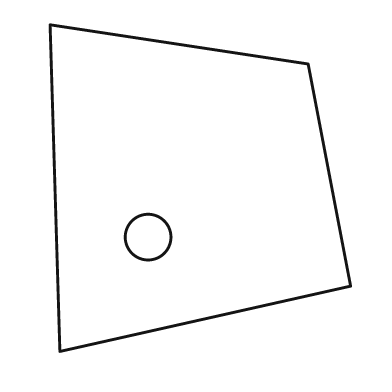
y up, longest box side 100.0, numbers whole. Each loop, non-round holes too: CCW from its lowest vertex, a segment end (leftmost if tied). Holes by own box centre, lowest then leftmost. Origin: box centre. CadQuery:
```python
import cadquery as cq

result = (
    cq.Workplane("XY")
    .moveTo(-43.0, -50.0)
    .lineTo(46.0, -30.0)
    .lineTo(33.0, 38.0)
    .lineTo(-46.0, 50.0)
    .close()
    .moveTo(-16.0, -15.0)
    .circle(7.0)
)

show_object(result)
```